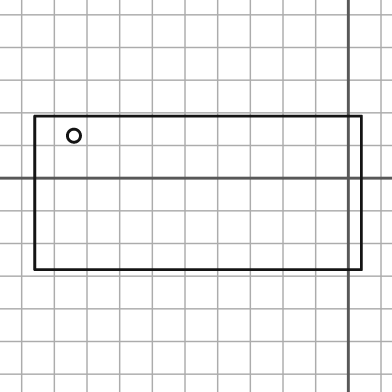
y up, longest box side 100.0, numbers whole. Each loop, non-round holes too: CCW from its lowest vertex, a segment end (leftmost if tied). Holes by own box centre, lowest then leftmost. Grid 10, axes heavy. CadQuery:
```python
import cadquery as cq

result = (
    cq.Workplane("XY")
    .moveTo(-96.0, -28.0)
    .lineTo(4.0, -28.0)
    .lineTo(4.0, 19.0)
    .lineTo(-96.0, 19.0)
    .close()
    .moveTo(-84.0, 13.0)
    .circle(2.0)
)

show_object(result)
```